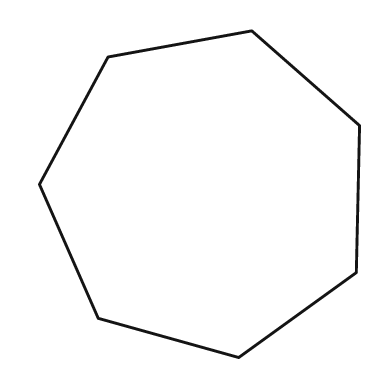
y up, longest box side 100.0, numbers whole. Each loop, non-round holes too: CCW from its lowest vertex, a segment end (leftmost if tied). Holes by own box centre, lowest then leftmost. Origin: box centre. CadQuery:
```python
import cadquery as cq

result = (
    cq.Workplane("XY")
    .moveTo(12.0, -50.0)
    .lineTo(48.0, -24.0)
    .lineTo(49.0, 21.0)
    .lineTo(16.0, 50.0)
    .lineTo(-28.0, 42.0)
    .lineTo(-49.0, 3.0)
    .lineTo(-31.0, -38.0)
    .close()
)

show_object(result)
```